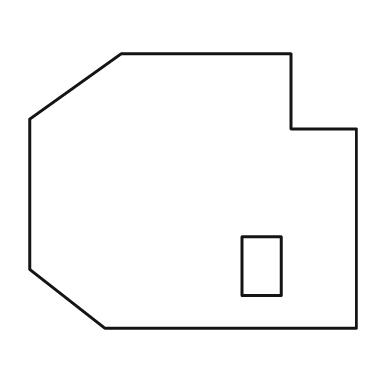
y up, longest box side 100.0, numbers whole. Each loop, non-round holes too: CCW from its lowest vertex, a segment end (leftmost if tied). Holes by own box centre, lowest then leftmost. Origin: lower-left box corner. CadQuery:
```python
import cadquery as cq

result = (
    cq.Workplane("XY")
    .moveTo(23.0, 0.0)
    .lineTo(100.0, 0.0)
    .lineTo(100.0, 61.0)
    .lineTo(80.0, 61.0)
    .lineTo(80.0, 84.0)
    .lineTo(28.0, 84.0)
    .lineTo(0.0, 64.0)
    .lineTo(0.0, 18.0)
    .close()
    .moveTo(65.0, 10.0)
    .lineTo(77.0, 10.0)
    .lineTo(77.0, 28.0)
    .lineTo(65.0, 28.0)
    .close()
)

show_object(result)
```